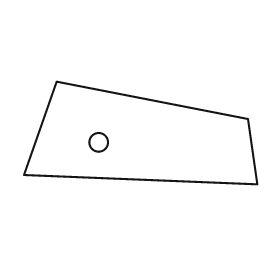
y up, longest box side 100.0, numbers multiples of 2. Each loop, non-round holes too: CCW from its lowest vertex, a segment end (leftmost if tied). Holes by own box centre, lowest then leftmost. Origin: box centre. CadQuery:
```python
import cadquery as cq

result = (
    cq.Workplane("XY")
    .moveTo(50.0, -22.0)
    .lineTo(46.0, 6.0)
    .lineTo(-36.0, 22.0)
    .lineTo(-50.0, -18.0)
    .close()
    .moveTo(-18.0, -4.0)
    .circle(4.0)
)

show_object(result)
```